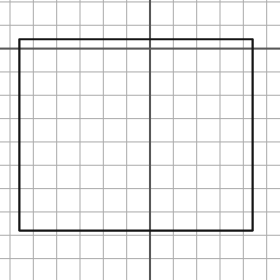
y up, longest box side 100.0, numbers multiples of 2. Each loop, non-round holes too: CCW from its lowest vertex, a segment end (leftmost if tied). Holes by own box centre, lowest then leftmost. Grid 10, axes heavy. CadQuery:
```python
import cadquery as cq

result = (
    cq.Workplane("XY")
    .moveTo(-56.0, -78.0)
    .lineTo(44.0, -78.0)
    .lineTo(44.0, 4.0)
    .lineTo(-56.0, 4.0)
    .close()
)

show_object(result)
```